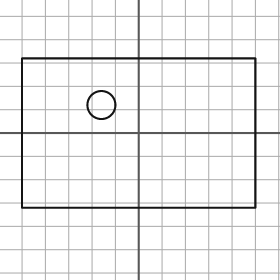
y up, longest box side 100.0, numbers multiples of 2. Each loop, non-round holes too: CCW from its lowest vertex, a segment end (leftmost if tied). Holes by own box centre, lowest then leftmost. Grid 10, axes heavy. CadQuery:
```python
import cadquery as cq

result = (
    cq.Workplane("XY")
    .moveTo(-50.0, -32.0)
    .lineTo(50.0, -32.0)
    .lineTo(50.0, 32.0)
    .lineTo(-50.0, 32.0)
    .close()
    .moveTo(-16.0, 12.0)
    .circle(6.0)
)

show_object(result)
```